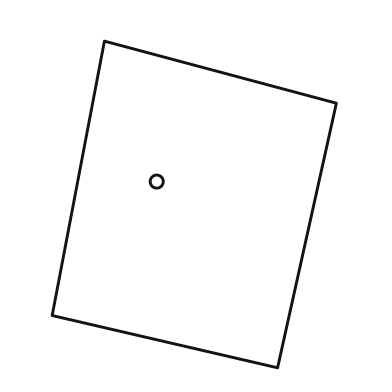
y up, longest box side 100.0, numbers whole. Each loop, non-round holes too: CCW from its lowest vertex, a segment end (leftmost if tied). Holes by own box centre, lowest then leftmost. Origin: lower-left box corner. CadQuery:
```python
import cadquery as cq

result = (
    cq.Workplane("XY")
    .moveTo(69.0, 0.0)
    .lineTo(87.0, 81.0)
    .lineTo(16.0, 100.0)
    .lineTo(0.0, 16.0)
    .close()
    .moveTo(32.0, 57.0)
    .circle(2.0)
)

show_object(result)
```